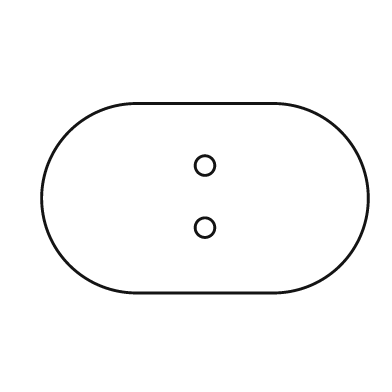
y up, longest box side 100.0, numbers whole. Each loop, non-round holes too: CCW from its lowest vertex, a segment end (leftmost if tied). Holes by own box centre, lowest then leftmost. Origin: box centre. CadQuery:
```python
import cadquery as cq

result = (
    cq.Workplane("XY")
    .moveTo(-21.0, -29.0)
    .lineTo(21.0, -29.0)
    .threePointArc((50.0, 0.0), (21.0, 29.0))
    .lineTo(-21.0, 29.0)
    .threePointArc((-50.0, 0.0), (-21.0, -29.0))
    .close()
    .moveTo(0.0, -9.0)
    .circle(3.0)
    .moveTo(0.0, 10.0)
    .circle(3.0)
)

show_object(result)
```